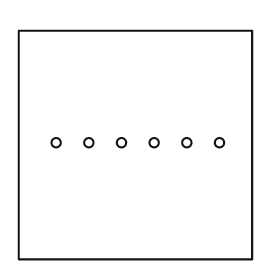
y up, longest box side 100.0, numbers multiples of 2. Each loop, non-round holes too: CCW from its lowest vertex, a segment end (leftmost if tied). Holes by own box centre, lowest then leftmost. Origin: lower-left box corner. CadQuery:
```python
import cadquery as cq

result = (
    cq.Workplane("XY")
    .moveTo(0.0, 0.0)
    .lineTo(100.0, 0.0)
    .lineTo(100.0, 98.0)
    .lineTo(0.0, 98.0)
    .close()
    .moveTo(16.0, 50.0)
    .circle(2.0)
    .moveTo(30.0, 50.0)
    .circle(2.0)
    .moveTo(44.0, 50.0)
    .circle(2.0)
    .moveTo(58.0, 50.0)
    .circle(2.0)
    .moveTo(72.0, 50.0)
    .circle(2.0)
    .moveTo(86.0, 50.0)
    .circle(2.0)
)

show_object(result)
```